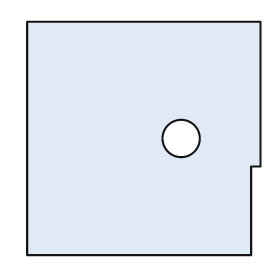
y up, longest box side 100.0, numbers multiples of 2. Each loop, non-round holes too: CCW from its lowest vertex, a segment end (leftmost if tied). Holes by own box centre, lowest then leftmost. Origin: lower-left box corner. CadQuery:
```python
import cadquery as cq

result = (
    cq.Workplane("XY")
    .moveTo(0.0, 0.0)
    .lineTo(96.0, 0.0)
    .lineTo(96.0, 38.0)
    .lineTo(100.0, 38.0)
    .lineTo(100.0, 100.0)
    .lineTo(0.0, 100.0)
    .close()
    .moveTo(66.0, 50.0)
    .circle(8.0)
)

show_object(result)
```